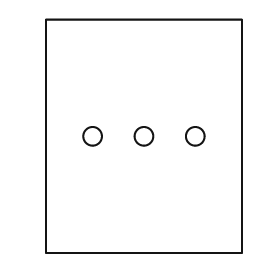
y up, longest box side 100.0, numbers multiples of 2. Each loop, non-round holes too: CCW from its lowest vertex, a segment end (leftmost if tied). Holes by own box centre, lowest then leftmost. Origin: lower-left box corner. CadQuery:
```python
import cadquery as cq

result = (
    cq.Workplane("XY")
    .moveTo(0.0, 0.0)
    .lineTo(84.0, 0.0)
    .lineTo(84.0, 100.0)
    .lineTo(0.0, 100.0)
    .close()
    .moveTo(20.0, 50.0)
    .circle(4.0)
    .moveTo(42.0, 50.0)
    .circle(4.0)
    .moveTo(64.0, 50.0)
    .circle(4.0)
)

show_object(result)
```